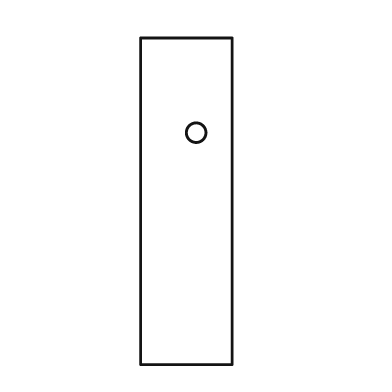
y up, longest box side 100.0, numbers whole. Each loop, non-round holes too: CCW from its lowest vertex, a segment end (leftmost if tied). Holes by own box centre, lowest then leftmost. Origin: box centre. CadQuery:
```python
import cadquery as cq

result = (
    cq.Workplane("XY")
    .moveTo(-14.0, -50.0)
    .lineTo(14.0, -50.0)
    .lineTo(14.0, 50.0)
    .lineTo(-14.0, 50.0)
    .close()
    .moveTo(3.0, 21.0)
    .circle(3.0)
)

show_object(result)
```